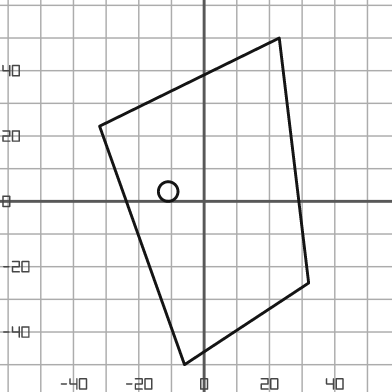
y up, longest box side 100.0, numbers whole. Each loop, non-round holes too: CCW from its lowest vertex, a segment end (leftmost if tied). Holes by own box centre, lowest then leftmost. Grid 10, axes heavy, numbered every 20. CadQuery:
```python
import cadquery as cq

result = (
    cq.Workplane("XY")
    .moveTo(-6.0, -50.0)
    .lineTo(32.0, -25.0)
    .lineTo(23.0, 50.0)
    .lineTo(-32.0, 23.0)
    .close()
    .moveTo(-11.0, 3.0)
    .circle(3.0)
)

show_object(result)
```